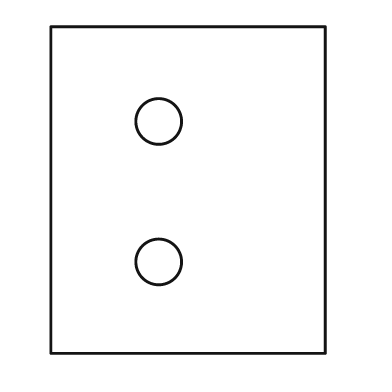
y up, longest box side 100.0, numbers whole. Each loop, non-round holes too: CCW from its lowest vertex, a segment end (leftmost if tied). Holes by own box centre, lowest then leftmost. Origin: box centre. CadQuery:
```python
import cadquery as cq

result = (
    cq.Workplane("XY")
    .moveTo(-42.0, -50.0)
    .lineTo(42.0, -50.0)
    .lineTo(42.0, 50.0)
    .lineTo(-42.0, 50.0)
    .close()
    .moveTo(-9.0, -22.0)
    .circle(7.0)
    .moveTo(-9.0, 21.0)
    .circle(7.0)
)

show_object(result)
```